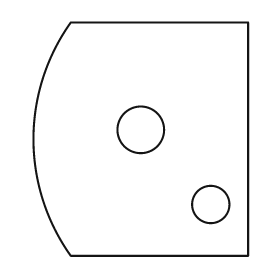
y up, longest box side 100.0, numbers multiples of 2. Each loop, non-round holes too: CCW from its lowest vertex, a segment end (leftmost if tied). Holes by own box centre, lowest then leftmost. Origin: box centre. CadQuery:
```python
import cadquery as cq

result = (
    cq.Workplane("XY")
    .moveTo(-30.0, -50.0)
    .lineTo(46.0, -50.0)
    .lineTo(46.0, 50.0)
    .lineTo(-30.0, 50.0)
    .threePointArc((-46.0, 0.0), (-30.0, -50.0))
    .close()
    .moveTo(30.0, -28.0)
    .circle(8.0)
    .moveTo(0.0, 4.0)
    .circle(10.0)
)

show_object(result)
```